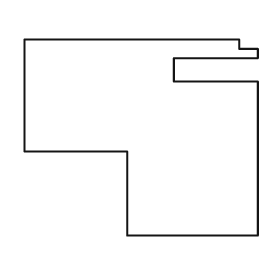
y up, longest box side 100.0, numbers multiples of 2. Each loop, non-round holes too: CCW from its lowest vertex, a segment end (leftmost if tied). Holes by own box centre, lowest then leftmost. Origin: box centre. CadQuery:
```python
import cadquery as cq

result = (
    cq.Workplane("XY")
    .moveTo(-6.0, -42.0)
    .lineTo(50.0, -42.0)
    .lineTo(50.0, 24.0)
    .lineTo(14.0, 24.0)
    .lineTo(14.0, 34.0)
    .lineTo(50.0, 34.0)
    .lineTo(50.0, 38.0)
    .lineTo(42.0, 38.0)
    .lineTo(42.0, 42.0)
    .lineTo(-50.0, 42.0)
    .lineTo(-50.0, -6.0)
    .lineTo(-6.0, -6.0)
    .close()
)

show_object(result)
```